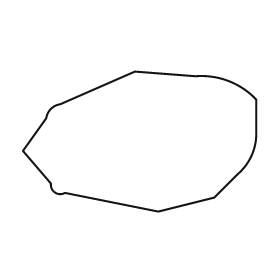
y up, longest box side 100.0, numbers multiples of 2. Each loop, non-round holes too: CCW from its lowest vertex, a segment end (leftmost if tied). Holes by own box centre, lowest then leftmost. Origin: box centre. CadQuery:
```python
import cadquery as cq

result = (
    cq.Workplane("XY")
    .moveTo(8.0, -30.0)
    .lineTo(32.0, -24.0)
    .lineTo(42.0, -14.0)
    .threePointArc((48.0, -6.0), (50.0, 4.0))
    .lineTo(50.0, 18.0)
    .threePointArc((38.0, 26.0), (24.0, 28.0))
    .lineTo(-2.0, 30.0)
    .lineTo(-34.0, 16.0)
    .threePointArc((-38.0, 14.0), (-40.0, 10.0))
    .lineTo(-50.0, -4.0)
    .lineTo(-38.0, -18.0)
    .threePointArc((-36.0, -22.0), (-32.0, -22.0))
    .close()
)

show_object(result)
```